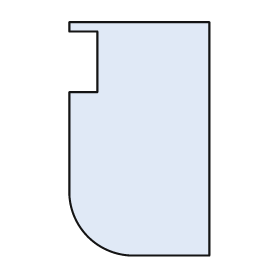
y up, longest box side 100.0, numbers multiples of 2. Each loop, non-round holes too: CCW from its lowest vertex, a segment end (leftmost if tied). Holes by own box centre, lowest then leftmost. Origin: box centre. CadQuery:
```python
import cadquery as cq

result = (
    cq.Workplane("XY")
    .moveTo(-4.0, -50.0)
    .lineTo(30.0, -50.0)
    .lineTo(30.0, 50.0)
    .lineTo(-30.0, 50.0)
    .lineTo(-30.0, 46.0)
    .lineTo(-18.0, 46.0)
    .lineTo(-18.0, 20.0)
    .lineTo(-30.0, 20.0)
    .lineTo(-30.0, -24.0)
    .threePointArc((-22.0, -42.0), (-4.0, -50.0))
    .close()
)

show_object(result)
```